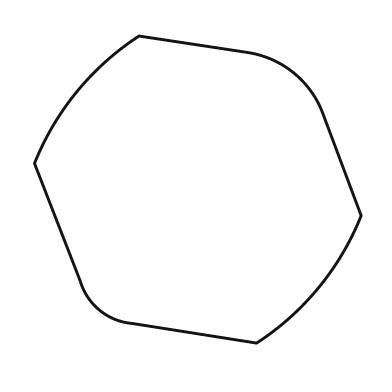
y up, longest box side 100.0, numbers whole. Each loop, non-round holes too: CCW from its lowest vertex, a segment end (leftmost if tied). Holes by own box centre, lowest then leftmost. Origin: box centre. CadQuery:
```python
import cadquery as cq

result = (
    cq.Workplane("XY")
    .moveTo(18.0, -47.0)
    .threePointArc((37.0, -30.0), (50.0, -8.0))
    .lineTo(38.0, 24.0)
    .threePointArc((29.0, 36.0), (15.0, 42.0))
    .lineTo(-18.0, 47.0)
    .threePointArc((-37.0, 30.0), (-50.0, 8.0))
    .lineTo(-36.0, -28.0)
    .threePointArc((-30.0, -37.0), (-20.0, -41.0))
    .close()
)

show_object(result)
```